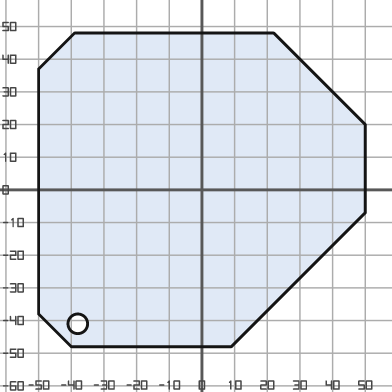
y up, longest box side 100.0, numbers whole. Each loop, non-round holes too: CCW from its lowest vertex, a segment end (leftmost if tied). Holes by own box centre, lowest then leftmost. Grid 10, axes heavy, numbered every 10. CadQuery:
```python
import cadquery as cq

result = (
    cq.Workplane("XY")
    .moveTo(-40.0, -48.0)
    .lineTo(9.0, -48.0)
    .lineTo(50.0, -7.0)
    .lineTo(50.0, 20.0)
    .lineTo(22.0, 48.0)
    .lineTo(-39.0, 48.0)
    .lineTo(-50.0, 37.0)
    .lineTo(-50.0, -38.0)
    .close()
    .moveTo(-38.0, -41.0)
    .circle(3.0)
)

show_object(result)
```